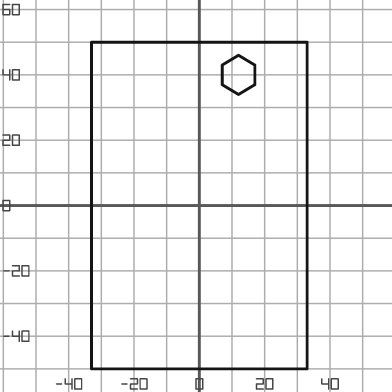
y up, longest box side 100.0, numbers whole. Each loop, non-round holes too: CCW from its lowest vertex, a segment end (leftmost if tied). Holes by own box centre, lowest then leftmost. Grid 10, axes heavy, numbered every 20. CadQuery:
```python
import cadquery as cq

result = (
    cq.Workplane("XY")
    .moveTo(-33.0, -50.0)
    .lineTo(33.0, -50.0)
    .lineTo(33.0, 50.0)
    .lineTo(-33.0, 50.0)
    .close()
    .moveTo(12.0, 34.0)
    .lineTo(17.0, 37.0)
    .lineTo(17.0, 43.0)
    .lineTo(12.0, 46.0)
    .lineTo(7.0, 43.0)
    .lineTo(7.0, 37.0)
    .close()
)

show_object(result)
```